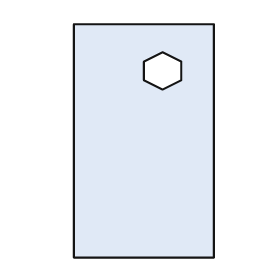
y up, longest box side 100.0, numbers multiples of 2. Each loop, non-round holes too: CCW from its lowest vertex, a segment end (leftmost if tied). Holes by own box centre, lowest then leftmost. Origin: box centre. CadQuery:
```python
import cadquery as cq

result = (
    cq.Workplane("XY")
    .moveTo(-30.0, -50.0)
    .lineTo(30.0, -50.0)
    .lineTo(30.0, 50.0)
    .lineTo(-30.0, 50.0)
    .close()
    .moveTo(8.0, 22.0)
    .lineTo(16.0, 26.0)
    .lineTo(16.0, 34.0)
    .lineTo(8.0, 38.0)
    .lineTo(0.0, 34.0)
    .lineTo(0.0, 26.0)
    .close()
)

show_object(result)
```